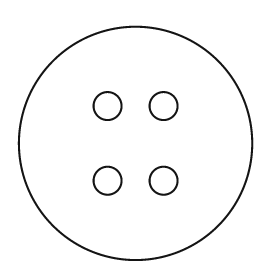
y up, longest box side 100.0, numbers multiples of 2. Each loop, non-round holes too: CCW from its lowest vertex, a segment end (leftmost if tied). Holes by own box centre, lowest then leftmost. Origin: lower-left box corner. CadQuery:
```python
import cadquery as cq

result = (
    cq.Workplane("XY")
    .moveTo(50.0, 50.0)
    .circle(50.0)
    .moveTo(38.0, 34.0)
    .circle(6.0)
    .moveTo(62.0, 34.0)
    .circle(6.0)
    .moveTo(38.0, 66.0)
    .circle(6.0)
    .moveTo(62.0, 66.0)
    .circle(6.0)
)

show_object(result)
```